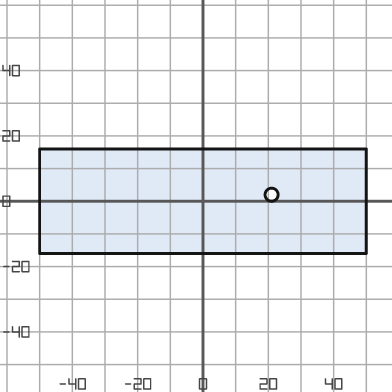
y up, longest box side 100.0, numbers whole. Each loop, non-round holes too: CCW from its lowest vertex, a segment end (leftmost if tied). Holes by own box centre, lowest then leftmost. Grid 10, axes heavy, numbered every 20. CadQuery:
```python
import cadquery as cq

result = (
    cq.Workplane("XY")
    .moveTo(-50.0, -16.0)
    .lineTo(50.0, -16.0)
    .lineTo(50.0, 16.0)
    .lineTo(-50.0, 16.0)
    .close()
    .moveTo(21.0, 2.0)
    .circle(2.0)
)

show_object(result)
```